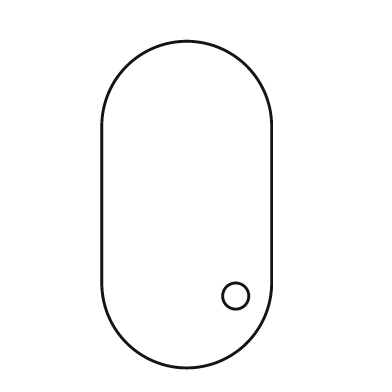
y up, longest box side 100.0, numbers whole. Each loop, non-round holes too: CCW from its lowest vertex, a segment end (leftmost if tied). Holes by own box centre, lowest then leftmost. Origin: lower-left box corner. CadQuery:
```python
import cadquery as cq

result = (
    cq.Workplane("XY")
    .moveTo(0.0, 26.0)
    .threePointArc((26.0, 0.0), (52.0, 26.0))
    .lineTo(52.0, 74.0)
    .threePointArc((26.0, 100.0), (0.0, 74.0))
    .close()
    .moveTo(41.0, 22.0)
    .circle(4.0)
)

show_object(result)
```